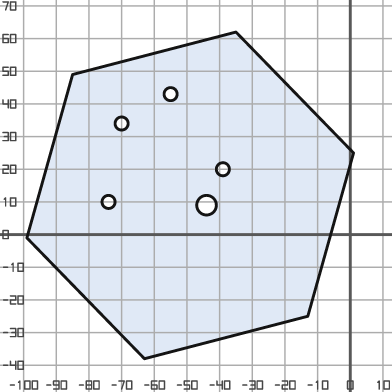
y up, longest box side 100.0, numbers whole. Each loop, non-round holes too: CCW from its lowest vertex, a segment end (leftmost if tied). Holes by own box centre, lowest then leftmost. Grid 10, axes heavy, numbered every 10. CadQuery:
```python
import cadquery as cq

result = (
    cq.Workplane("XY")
    .moveTo(-63.0, -38.0)
    .lineTo(-13.0, -25.0)
    .lineTo(1.0, 25.0)
    .lineTo(-35.0, 62.0)
    .lineTo(-85.0, 49.0)
    .lineTo(-99.0, -1.0)
    .close()
    .moveTo(-44.0, 9.0)
    .circle(3.0)
    .moveTo(-74.0, 10.0)
    .circle(2.0)
    .moveTo(-39.0, 20.0)
    .circle(2.0)
    .moveTo(-70.0, 34.0)
    .circle(2.0)
    .moveTo(-55.0, 43.0)
    .circle(2.0)
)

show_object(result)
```